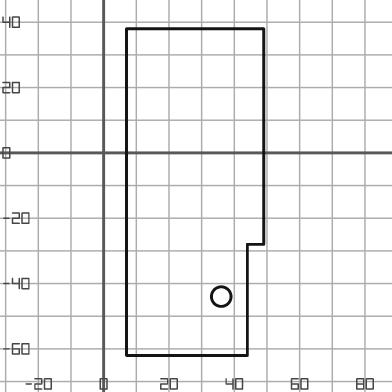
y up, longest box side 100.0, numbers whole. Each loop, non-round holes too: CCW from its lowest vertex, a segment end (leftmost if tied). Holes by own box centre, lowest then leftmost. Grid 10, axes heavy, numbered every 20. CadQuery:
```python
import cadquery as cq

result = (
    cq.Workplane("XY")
    .moveTo(7.0, -62.0)
    .lineTo(44.0, -62.0)
    .lineTo(44.0, -28.0)
    .lineTo(49.0, -28.0)
    .lineTo(49.0, 38.0)
    .lineTo(7.0, 38.0)
    .close()
    .moveTo(36.0, -44.0)
    .circle(3.0)
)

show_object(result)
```